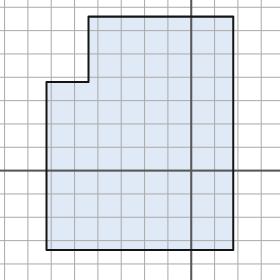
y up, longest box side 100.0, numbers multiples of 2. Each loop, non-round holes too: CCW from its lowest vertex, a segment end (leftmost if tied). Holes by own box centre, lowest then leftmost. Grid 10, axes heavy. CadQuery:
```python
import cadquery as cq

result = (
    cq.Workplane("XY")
    .moveTo(-62.0, -34.0)
    .lineTo(18.0, -34.0)
    .lineTo(18.0, 66.0)
    .lineTo(-44.0, 66.0)
    .lineTo(-44.0, 38.0)
    .lineTo(-62.0, 38.0)
    .close()
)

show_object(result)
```